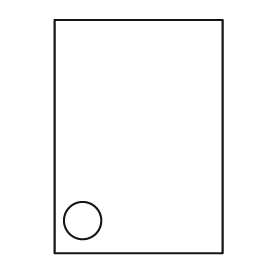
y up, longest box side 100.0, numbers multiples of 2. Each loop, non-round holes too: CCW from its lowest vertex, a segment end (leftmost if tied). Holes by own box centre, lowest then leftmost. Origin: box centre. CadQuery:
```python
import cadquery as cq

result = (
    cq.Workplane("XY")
    .moveTo(-36.0, -50.0)
    .lineTo(36.0, -50.0)
    .lineTo(36.0, 50.0)
    .lineTo(-36.0, 50.0)
    .close()
    .moveTo(-24.0, -36.0)
    .circle(8.0)
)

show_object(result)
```